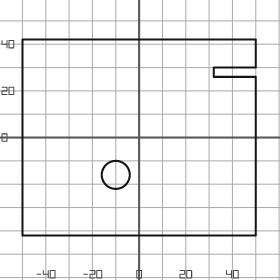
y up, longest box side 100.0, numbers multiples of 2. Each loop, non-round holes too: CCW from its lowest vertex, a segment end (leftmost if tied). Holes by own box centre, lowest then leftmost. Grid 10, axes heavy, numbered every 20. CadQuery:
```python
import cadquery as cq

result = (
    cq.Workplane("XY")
    .moveTo(-50.0, -42.0)
    .lineTo(50.0, -42.0)
    .lineTo(50.0, 26.0)
    .lineTo(32.0, 26.0)
    .lineTo(32.0, 30.0)
    .lineTo(50.0, 30.0)
    .lineTo(50.0, 42.0)
    .lineTo(-50.0, 42.0)
    .close()
    .moveTo(-10.0, -16.0)
    .circle(6.0)
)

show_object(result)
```